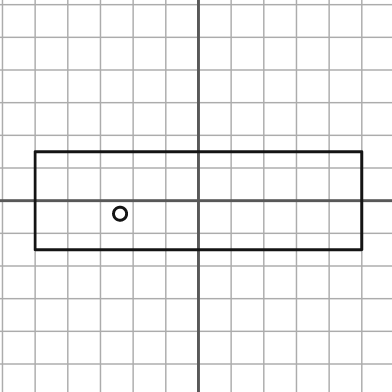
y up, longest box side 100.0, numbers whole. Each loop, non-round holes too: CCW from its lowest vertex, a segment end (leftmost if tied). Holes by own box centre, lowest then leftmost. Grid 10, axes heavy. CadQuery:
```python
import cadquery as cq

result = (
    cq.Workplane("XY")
    .moveTo(-50.0, -15.0)
    .lineTo(50.0, -15.0)
    .lineTo(50.0, 15.0)
    .lineTo(-50.0, 15.0)
    .close()
    .moveTo(-24.0, -4.0)
    .circle(2.0)
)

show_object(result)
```